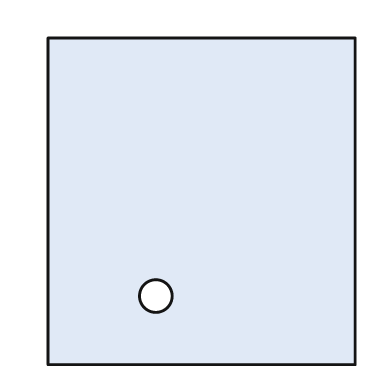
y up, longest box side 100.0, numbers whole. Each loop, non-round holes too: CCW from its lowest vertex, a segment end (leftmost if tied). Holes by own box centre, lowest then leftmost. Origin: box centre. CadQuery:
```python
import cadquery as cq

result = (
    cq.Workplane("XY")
    .moveTo(-47.0, -50.0)
    .lineTo(47.0, -50.0)
    .lineTo(47.0, 50.0)
    .lineTo(-47.0, 50.0)
    .close()
    .moveTo(-14.0, -29.0)
    .circle(5.0)
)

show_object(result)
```